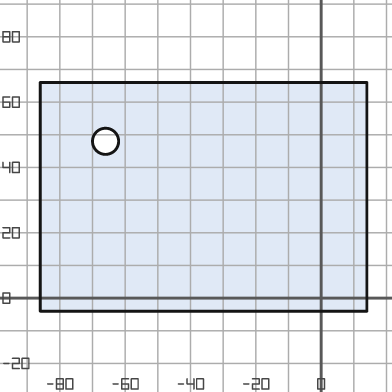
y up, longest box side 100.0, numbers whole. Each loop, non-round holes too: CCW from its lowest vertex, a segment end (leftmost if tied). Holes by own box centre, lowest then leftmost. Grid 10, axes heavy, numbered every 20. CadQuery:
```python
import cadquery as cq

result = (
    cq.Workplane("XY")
    .moveTo(-86.0, -4.0)
    .lineTo(14.0, -4.0)
    .lineTo(14.0, 66.0)
    .lineTo(-86.0, 66.0)
    .close()
    .moveTo(-66.0, 48.0)
    .circle(4.0)
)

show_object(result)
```